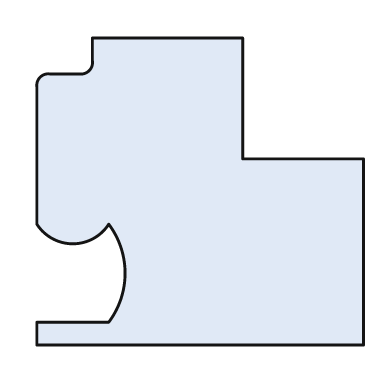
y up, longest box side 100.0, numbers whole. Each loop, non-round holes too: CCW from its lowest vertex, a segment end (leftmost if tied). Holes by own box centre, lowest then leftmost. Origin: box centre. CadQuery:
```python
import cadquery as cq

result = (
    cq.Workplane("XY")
    .moveTo(-50.0, -47.0)
    .lineTo(50.0, -47.0)
    .lineTo(50.0, 10.0)
    .lineTo(13.0, 10.0)
    .lineTo(13.0, 47.0)
    .lineTo(-33.0, 47.0)
    .lineTo(-33.0, 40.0)
    .threePointArc((-34.0, 37.0), (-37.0, 36.0))
    .lineTo(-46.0, 36.0)
    .threePointArc((-49.0, 35.0), (-50.0, 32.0))
    .lineTo(-50.0, -10.0)
    .threePointArc((-39.0, -16.0), (-28.0, -10.0))
    .threePointArc((-23.0, -25.0), (-28.0, -40.0))
    .lineTo(-50.0, -40.0)
    .close()
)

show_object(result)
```